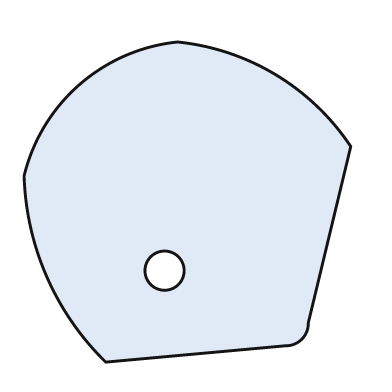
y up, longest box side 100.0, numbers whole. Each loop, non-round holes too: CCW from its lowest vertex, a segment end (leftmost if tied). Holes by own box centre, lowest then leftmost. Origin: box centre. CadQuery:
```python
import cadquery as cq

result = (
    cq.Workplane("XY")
    .moveTo(-25.0, -49.0)
    .lineTo(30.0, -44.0)
    .threePointArc((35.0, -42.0), (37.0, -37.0))
    .lineTo(50.0, 17.0)
    .threePointArc((27.0, 39.0), (-3.0, 49.0))
    .threePointArc((-33.0, 36.0), (-50.0, 8.0))
    .threePointArc((-43.0, -23.0), (-25.0, -49.0))
    .close()
    .moveTo(-7.0, -21.0)
    .circle(6.0)
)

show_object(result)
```